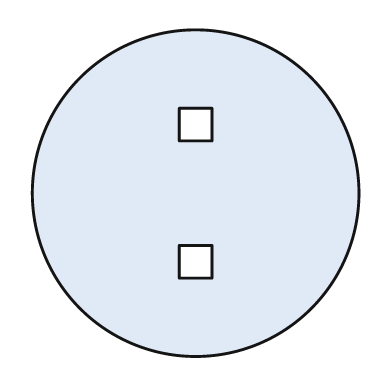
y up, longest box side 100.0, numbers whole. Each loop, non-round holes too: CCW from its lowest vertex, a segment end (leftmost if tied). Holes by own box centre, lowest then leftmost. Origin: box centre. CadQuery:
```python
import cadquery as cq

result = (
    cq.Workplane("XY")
    .moveTo(0.0, 0.0)
    .circle(50.0)
    .moveTo(-5.0, -26.0)
    .lineTo(5.0, -26.0)
    .lineTo(5.0, -16.0)
    .lineTo(-5.0, -16.0)
    .close()
    .moveTo(-5.0, 16.0)
    .lineTo(5.0, 16.0)
    .lineTo(5.0, 26.0)
    .lineTo(-5.0, 26.0)
    .close()
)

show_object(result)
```